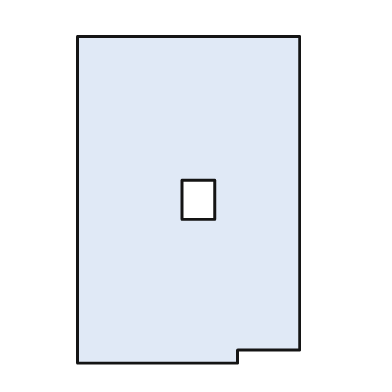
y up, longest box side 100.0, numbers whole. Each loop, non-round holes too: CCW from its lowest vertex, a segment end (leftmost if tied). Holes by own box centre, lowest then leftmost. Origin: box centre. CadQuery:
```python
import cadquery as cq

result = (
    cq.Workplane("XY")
    .moveTo(-34.0, -50.0)
    .lineTo(15.0, -50.0)
    .lineTo(15.0, -46.0)
    .lineTo(34.0, -46.0)
    .lineTo(34.0, 50.0)
    .lineTo(-34.0, 50.0)
    .close()
    .moveTo(-2.0, -6.0)
    .lineTo(8.0, -6.0)
    .lineTo(8.0, 6.0)
    .lineTo(-2.0, 6.0)
    .close()
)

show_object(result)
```